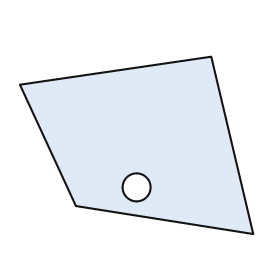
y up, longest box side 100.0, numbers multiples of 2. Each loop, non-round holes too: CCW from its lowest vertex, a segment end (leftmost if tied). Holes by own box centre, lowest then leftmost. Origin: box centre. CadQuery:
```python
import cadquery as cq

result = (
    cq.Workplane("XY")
    .moveTo(50.0, -38.0)
    .lineTo(32.0, 38.0)
    .lineTo(-50.0, 26.0)
    .lineTo(-26.0, -26.0)
    .close()
    .moveTo(0.0, -18.0)
    .circle(6.0)
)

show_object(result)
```